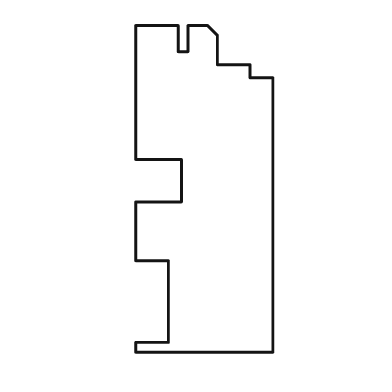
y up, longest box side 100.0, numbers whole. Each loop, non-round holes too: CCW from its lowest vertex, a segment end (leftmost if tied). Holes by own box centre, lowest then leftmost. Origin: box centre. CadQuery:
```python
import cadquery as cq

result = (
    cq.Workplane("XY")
    .moveTo(-21.0, -50.0)
    .lineTo(21.0, -50.0)
    .lineTo(21.0, 34.0)
    .lineTo(14.0, 34.0)
    .lineTo(14.0, 38.0)
    .lineTo(4.0, 38.0)
    .lineTo(4.0, 47.0)
    .lineTo(1.0, 50.0)
    .lineTo(-5.0, 50.0)
    .lineTo(-5.0, 42.0)
    .lineTo(-8.0, 42.0)
    .lineTo(-8.0, 50.0)
    .lineTo(-21.0, 50.0)
    .lineTo(-21.0, 9.0)
    .lineTo(-7.0, 9.0)
    .lineTo(-7.0, -4.0)
    .lineTo(-21.0, -4.0)
    .lineTo(-21.0, -22.0)
    .lineTo(-11.0, -22.0)
    .lineTo(-11.0, -47.0)
    .lineTo(-21.0, -47.0)
    .close()
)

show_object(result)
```